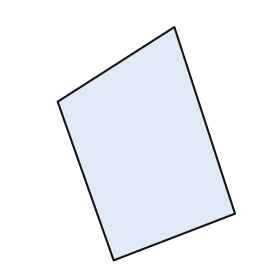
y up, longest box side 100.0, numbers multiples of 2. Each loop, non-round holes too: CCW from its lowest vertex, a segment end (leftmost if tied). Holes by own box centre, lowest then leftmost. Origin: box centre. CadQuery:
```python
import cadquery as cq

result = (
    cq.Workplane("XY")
    .moveTo(-14.0, -50.0)
    .lineTo(38.0, -30.0)
    .lineTo(12.0, 50.0)
    .lineTo(-38.0, 18.0)
    .close()
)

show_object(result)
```